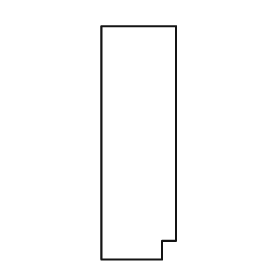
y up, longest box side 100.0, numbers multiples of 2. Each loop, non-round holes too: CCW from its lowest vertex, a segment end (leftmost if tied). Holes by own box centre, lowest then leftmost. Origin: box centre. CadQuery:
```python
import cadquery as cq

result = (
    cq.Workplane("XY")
    .moveTo(-16.0, -50.0)
    .lineTo(10.0, -50.0)
    .lineTo(10.0, -42.0)
    .lineTo(16.0, -42.0)
    .lineTo(16.0, 50.0)
    .lineTo(-16.0, 50.0)
    .close()
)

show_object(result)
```